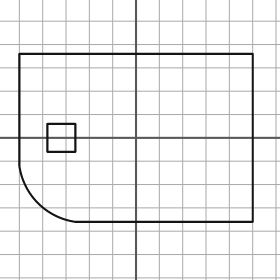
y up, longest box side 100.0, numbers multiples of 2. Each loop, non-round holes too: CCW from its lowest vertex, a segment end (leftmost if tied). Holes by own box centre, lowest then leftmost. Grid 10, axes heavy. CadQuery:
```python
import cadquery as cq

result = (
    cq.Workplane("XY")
    .moveTo(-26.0, -36.0)
    .lineTo(50.0, -36.0)
    .lineTo(50.0, 36.0)
    .lineTo(-50.0, 36.0)
    .lineTo(-50.0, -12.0)
    .threePointArc((-42.0, -28.0), (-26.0, -36.0))
    .close()
    .moveTo(-38.0, -6.0)
    .lineTo(-26.0, -6.0)
    .lineTo(-26.0, 6.0)
    .lineTo(-38.0, 6.0)
    .close()
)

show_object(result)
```